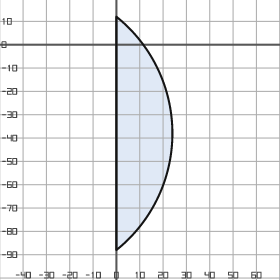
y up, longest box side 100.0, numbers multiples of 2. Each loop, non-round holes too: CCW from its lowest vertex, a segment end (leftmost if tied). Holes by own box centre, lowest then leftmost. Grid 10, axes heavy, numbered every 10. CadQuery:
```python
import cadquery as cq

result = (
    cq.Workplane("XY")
    .moveTo(0.0, -88.0)
    .threePointArc((24.0, -38.0), (0.0, 12.0))
    .close()
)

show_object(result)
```